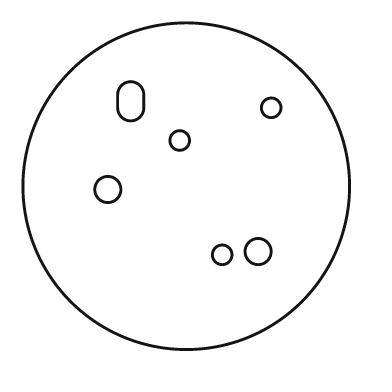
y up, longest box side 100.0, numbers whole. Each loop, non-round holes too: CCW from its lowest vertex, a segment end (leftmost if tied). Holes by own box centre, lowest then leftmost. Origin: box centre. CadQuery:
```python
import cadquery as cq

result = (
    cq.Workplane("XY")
    .moveTo(0.0, 0.0)
    .circle(50.0)
    .moveTo(11.0, -21.0)
    .circle(3.0)
    .moveTo(22.0, -20.0)
    .circle(4.0)
    .moveTo(-24.0, -1.0)
    .circle(4.0)
    .moveTo(-2.0, 14.0)
    .circle(3.0)
    .moveTo(26.0, 24.0)
    .circle(3.0)
    .moveTo(-21.0, 24.0)
    .threePointArc((-17.0, 20.0), (-13.0, 24.0))
    .lineTo(-13.0, 28.0)
    .threePointArc((-17.0, 32.0), (-21.0, 28.0))
    .close()
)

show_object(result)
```